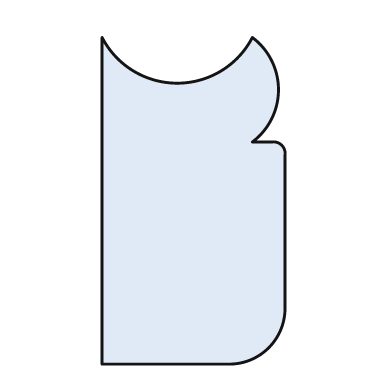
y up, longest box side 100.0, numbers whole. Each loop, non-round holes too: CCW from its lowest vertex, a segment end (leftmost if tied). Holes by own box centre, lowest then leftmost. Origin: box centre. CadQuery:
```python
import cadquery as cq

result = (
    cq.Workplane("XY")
    .moveTo(-28.0, -50.0)
    .lineTo(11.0, -50.0)
    .threePointArc((23.0, -45.0), (28.0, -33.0))
    .lineTo(28.0, 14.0)
    .threePointArc((27.0, 17.0), (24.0, 18.0))
    .lineTo(18.0, 18.0)
    .threePointArc((26.0, 34.0), (18.0, 50.0))
    .threePointArc((-5.0, 36.0), (-28.0, 50.0))
    .close()
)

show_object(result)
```